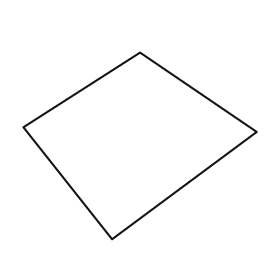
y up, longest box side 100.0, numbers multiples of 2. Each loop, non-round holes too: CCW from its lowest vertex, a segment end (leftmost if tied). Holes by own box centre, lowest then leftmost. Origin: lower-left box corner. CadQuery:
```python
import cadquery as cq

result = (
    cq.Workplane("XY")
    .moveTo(38.0, 0.0)
    .lineTo(100.0, 46.0)
    .lineTo(50.0, 80.0)
    .lineTo(0.0, 48.0)
    .close()
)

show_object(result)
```